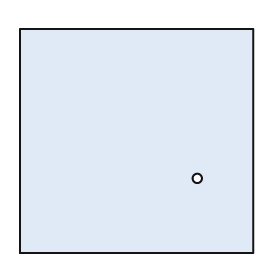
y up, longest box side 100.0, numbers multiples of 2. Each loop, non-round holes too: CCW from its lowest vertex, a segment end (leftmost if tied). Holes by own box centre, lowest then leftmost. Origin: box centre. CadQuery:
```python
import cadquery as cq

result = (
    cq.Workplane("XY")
    .moveTo(-50.0, -48.0)
    .lineTo(50.0, -48.0)
    .lineTo(50.0, 48.0)
    .lineTo(-50.0, 48.0)
    .close()
    .moveTo(26.0, -16.0)
    .circle(2.0)
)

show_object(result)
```